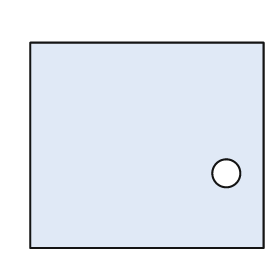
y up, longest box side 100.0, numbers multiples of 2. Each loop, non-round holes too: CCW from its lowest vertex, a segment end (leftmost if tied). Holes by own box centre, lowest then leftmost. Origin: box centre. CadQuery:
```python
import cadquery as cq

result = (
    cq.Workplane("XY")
    .moveTo(-50.0, -44.0)
    .lineTo(50.0, -44.0)
    .lineTo(50.0, 44.0)
    .lineTo(-50.0, 44.0)
    .close()
    .moveTo(34.0, -12.0)
    .circle(6.0)
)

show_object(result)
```